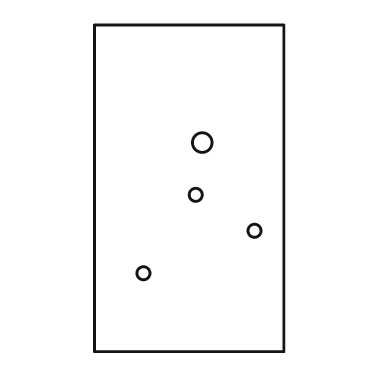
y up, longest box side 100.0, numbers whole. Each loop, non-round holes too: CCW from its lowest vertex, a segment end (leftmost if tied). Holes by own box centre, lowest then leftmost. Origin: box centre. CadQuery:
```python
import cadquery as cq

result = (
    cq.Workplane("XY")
    .moveTo(-29.0, -50.0)
    .lineTo(29.0, -50.0)
    .lineTo(29.0, 50.0)
    .lineTo(-29.0, 50.0)
    .close()
    .moveTo(-14.0, -26.0)
    .circle(2.0)
    .moveTo(20.0, -13.0)
    .circle(2.0)
    .moveTo(2.0, -2.0)
    .circle(2.0)
    .moveTo(4.0, 14.0)
    .circle(3.0)
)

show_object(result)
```